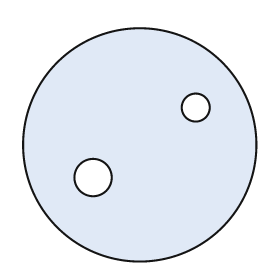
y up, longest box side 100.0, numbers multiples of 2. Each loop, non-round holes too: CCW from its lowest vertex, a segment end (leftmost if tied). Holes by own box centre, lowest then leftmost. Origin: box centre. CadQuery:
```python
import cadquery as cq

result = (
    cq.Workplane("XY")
    .moveTo(0.0, 0.0)
    .circle(50.0)
    .moveTo(-20.0, -14.0)
    .circle(8.0)
    .moveTo(24.0, 16.0)
    .circle(6.0)
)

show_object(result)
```